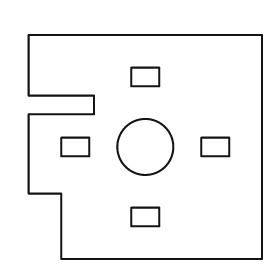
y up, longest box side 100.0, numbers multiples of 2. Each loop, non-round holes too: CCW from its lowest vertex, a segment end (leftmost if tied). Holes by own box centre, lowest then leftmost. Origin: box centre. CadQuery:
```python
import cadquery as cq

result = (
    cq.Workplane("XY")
    .moveTo(-36.0, -48.0)
    .lineTo(50.0, -48.0)
    .lineTo(50.0, 48.0)
    .lineTo(-50.0, 48.0)
    .lineTo(-50.0, 22.0)
    .lineTo(-22.0, 22.0)
    .lineTo(-22.0, 14.0)
    .lineTo(-50.0, 14.0)
    .lineTo(-50.0, -20.0)
    .lineTo(-36.0, -20.0)
    .close()
    .moveTo(-6.0, -34.0)
    .lineTo(6.0, -34.0)
    .lineTo(6.0, -26.0)
    .lineTo(-6.0, -26.0)
    .close()
    .moveTo(-36.0, -4.0)
    .lineTo(-24.0, -4.0)
    .lineTo(-24.0, 4.0)
    .lineTo(-36.0, 4.0)
    .close()
    .moveTo(0.0, 0.0)
    .circle(12.0)
    .moveTo(24.0, -4.0)
    .lineTo(36.0, -4.0)
    .lineTo(36.0, 4.0)
    .lineTo(24.0, 4.0)
    .close()
    .moveTo(-6.0, 26.0)
    .lineTo(6.0, 26.0)
    .lineTo(6.0, 34.0)
    .lineTo(-6.0, 34.0)
    .close()
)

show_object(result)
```